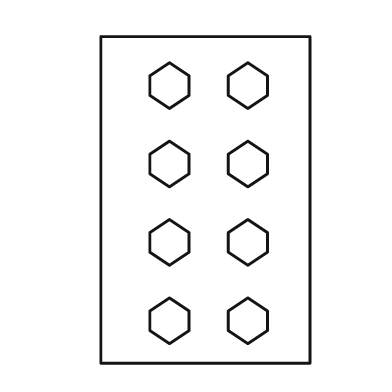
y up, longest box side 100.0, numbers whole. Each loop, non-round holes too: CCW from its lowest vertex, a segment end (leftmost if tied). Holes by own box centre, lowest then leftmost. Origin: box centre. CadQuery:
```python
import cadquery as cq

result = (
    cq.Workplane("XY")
    .moveTo(-32.0, -50.0)
    .lineTo(32.0, -50.0)
    .lineTo(32.0, 50.0)
    .lineTo(-32.0, 50.0)
    .close()
    .moveTo(-11.0, -44.0)
    .lineTo(-5.0, -40.0)
    .lineTo(-5.0, -34.0)
    .lineTo(-11.0, -30.0)
    .lineTo(-17.0, -34.0)
    .lineTo(-17.0, -40.0)
    .close()
    .moveTo(13.0, -44.0)
    .lineTo(19.0, -40.0)
    .lineTo(19.0, -34.0)
    .lineTo(13.0, -30.0)
    .lineTo(7.0, -34.0)
    .lineTo(7.0, -40.0)
    .close()
    .moveTo(-11.0, -20.0)
    .lineTo(-5.0, -16.0)
    .lineTo(-5.0, -10.0)
    .lineTo(-11.0, -6.0)
    .lineTo(-17.0, -10.0)
    .lineTo(-17.0, -16.0)
    .close()
    .moveTo(13.0, -20.0)
    .lineTo(19.0, -16.0)
    .lineTo(19.0, -10.0)
    .lineTo(13.0, -6.0)
    .lineTo(7.0, -10.0)
    .lineTo(7.0, -16.0)
    .close()
    .moveTo(-11.0, 4.0)
    .lineTo(-5.0, 8.0)
    .lineTo(-5.0, 14.0)
    .lineTo(-11.0, 18.0)
    .lineTo(-17.0, 14.0)
    .lineTo(-17.0, 8.0)
    .close()
    .moveTo(13.0, 4.0)
    .lineTo(19.0, 8.0)
    .lineTo(19.0, 14.0)
    .lineTo(13.0, 18.0)
    .lineTo(7.0, 14.0)
    .lineTo(7.0, 8.0)
    .close()
    .moveTo(-11.0, 28.0)
    .lineTo(-5.0, 32.0)
    .lineTo(-5.0, 38.0)
    .lineTo(-11.0, 42.0)
    .lineTo(-17.0, 38.0)
    .lineTo(-17.0, 32.0)
    .close()
    .moveTo(13.0, 28.0)
    .lineTo(19.0, 32.0)
    .lineTo(19.0, 38.0)
    .lineTo(13.0, 42.0)
    .lineTo(7.0, 38.0)
    .lineTo(7.0, 32.0)
    .close()
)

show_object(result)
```